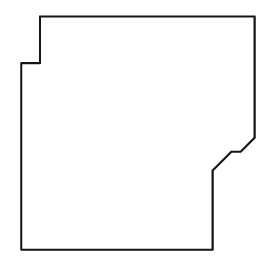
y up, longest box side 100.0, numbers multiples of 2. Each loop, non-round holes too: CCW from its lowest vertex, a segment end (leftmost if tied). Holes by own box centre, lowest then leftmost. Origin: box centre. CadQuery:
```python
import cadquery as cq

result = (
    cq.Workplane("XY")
    .moveTo(-50.0, -50.0)
    .lineTo(32.0, -50.0)
    .lineTo(32.0, -16.0)
    .lineTo(40.0, -8.0)
    .lineTo(44.0, -8.0)
    .lineTo(50.0, -2.0)
    .lineTo(50.0, 50.0)
    .lineTo(-42.0, 50.0)
    .lineTo(-42.0, 30.0)
    .lineTo(-50.0, 30.0)
    .close()
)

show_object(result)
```